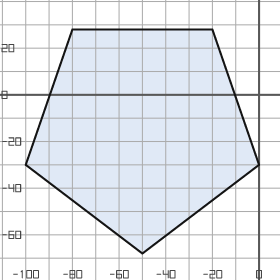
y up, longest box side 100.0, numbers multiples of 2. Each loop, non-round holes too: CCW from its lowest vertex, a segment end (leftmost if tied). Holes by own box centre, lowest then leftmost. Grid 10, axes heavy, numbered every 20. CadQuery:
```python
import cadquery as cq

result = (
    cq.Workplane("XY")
    .moveTo(-50.0, -68.0)
    .lineTo(0.0, -30.0)
    .lineTo(-20.0, 28.0)
    .lineTo(-80.0, 28.0)
    .lineTo(-100.0, -30.0)
    .close()
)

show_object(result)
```